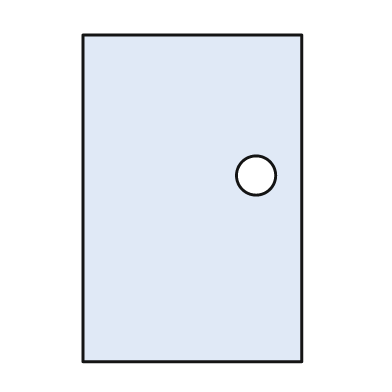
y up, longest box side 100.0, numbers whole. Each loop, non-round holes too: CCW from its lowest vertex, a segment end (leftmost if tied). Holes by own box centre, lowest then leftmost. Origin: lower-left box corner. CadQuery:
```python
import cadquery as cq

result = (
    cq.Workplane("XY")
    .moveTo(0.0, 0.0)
    .lineTo(67.0, 0.0)
    .lineTo(67.0, 100.0)
    .lineTo(0.0, 100.0)
    .close()
    .moveTo(53.0, 57.0)
    .circle(6.0)
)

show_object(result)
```